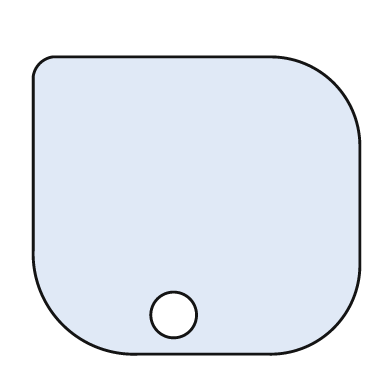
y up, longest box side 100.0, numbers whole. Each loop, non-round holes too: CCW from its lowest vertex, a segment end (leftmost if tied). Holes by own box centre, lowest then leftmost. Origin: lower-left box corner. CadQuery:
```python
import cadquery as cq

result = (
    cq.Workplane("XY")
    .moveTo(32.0, 0.0)
    .lineTo(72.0, 0.0)
    .threePointArc((92.0, 8.0), (100.0, 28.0))
    .lineTo(100.0, 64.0)
    .threePointArc((92.0, 83.0), (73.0, 91.0))
    .lineTo(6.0, 91.0)
    .threePointArc((2.0, 89.0), (0.0, 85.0))
    .lineTo(0.0, 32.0)
    .threePointArc((9.0, 9.0), (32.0, 0.0))
    .close()
    .moveTo(43.0, 12.0)
    .circle(7.0)
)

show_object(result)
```